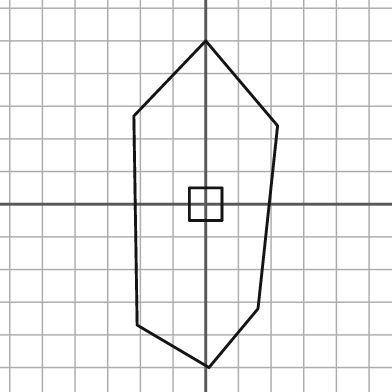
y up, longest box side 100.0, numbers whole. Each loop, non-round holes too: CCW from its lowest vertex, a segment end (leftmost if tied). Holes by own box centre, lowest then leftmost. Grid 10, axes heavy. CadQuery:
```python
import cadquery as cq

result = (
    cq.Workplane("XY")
    .moveTo(1.0, -50.0)
    .lineTo(16.0, -32.0)
    .lineTo(22.0, 24.0)
    .lineTo(0.0, 50.0)
    .lineTo(-22.0, 27.0)
    .lineTo(-21.0, -37.0)
    .close()
    .moveTo(-5.0, -5.0)
    .lineTo(5.0, -5.0)
    .lineTo(5.0, 5.0)
    .lineTo(-5.0, 5.0)
    .close()
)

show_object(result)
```